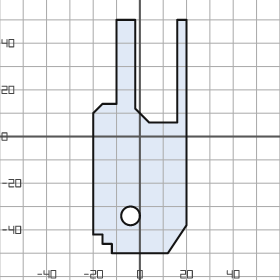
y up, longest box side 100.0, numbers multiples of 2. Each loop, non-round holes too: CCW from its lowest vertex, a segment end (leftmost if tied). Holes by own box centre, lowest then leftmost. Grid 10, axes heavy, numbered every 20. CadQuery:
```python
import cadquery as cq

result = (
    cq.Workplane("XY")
    .moveTo(-12.0, -50.0)
    .lineTo(12.0, -50.0)
    .lineTo(20.0, -38.0)
    .lineTo(20.0, 50.0)
    .lineTo(16.0, 50.0)
    .lineTo(16.0, 6.0)
    .lineTo(4.0, 6.0)
    .lineTo(-2.0, 12.0)
    .lineTo(-2.0, 50.0)
    .lineTo(-10.0, 50.0)
    .lineTo(-10.0, 14.0)
    .lineTo(-16.0, 14.0)
    .lineTo(-20.0, 10.0)
    .lineTo(-20.0, -42.0)
    .lineTo(-16.0, -42.0)
    .lineTo(-16.0, -46.0)
    .lineTo(-12.0, -46.0)
    .close()
    .moveTo(-4.0, -34.0)
    .circle(4.0)
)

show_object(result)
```